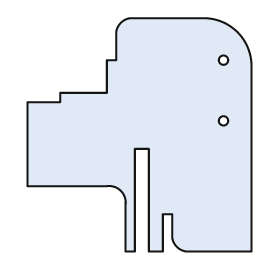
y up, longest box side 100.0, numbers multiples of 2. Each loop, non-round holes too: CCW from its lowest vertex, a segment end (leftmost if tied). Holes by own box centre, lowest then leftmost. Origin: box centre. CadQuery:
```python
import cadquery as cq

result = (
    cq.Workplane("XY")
    .moveTo(-6.0, -50.0)
    .lineTo(-2.0, -50.0)
    .lineTo(-2.0, -6.0)
    .lineTo(4.0, -6.0)
    .lineTo(4.0, -50.0)
    .lineTo(10.0, -50.0)
    .lineTo(10.0, -34.0)
    .lineTo(14.0, -34.0)
    .lineTo(14.0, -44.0)
    .threePointArc((16.0, -48.0), (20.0, -50.0))
    .lineTo(48.0, -50.0)
    .lineTo(48.0, 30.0)
    .threePointArc((42.0, 44.0), (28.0, 50.0))
    .lineTo(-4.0, 50.0)
    .threePointArc((-8.0, 48.0), (-10.0, 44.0))
    .lineTo(-10.0, 32.0)
    .lineTo(-14.0, 32.0)
    .lineTo(-14.0, 18.0)
    .lineTo(-34.0, 18.0)
    .lineTo(-34.0, 14.0)
    .lineTo(-48.0, 14.0)
    .lineTo(-48.0, -22.0)
    .lineTo(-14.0, -22.0)
    .threePointArc((-8.0, -24.0), (-6.0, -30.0))
    .close()
    .moveTo(36.0, 6.0)
    .circle(2.0)
    .moveTo(36.0, 32.0)
    .circle(2.0)
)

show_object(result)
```